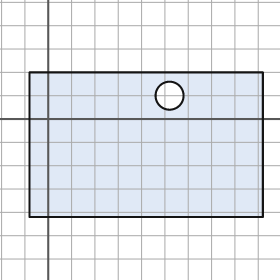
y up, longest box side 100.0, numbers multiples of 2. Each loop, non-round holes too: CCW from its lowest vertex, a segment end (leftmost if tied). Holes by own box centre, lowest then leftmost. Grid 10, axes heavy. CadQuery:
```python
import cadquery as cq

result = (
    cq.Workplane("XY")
    .moveTo(-8.0, -42.0)
    .lineTo(92.0, -42.0)
    .lineTo(92.0, 20.0)
    .lineTo(-8.0, 20.0)
    .close()
    .moveTo(52.0, 10.0)
    .circle(6.0)
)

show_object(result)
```